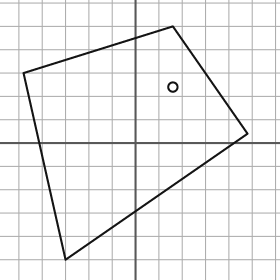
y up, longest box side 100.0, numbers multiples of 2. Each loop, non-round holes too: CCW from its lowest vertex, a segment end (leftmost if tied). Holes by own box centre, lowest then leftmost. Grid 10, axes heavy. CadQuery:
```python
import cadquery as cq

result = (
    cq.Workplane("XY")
    .moveTo(-30.0, -50.0)
    .lineTo(48.0, 4.0)
    .lineTo(16.0, 50.0)
    .lineTo(-48.0, 30.0)
    .close()
    .moveTo(16.0, 24.0)
    .circle(2.0)
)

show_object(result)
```